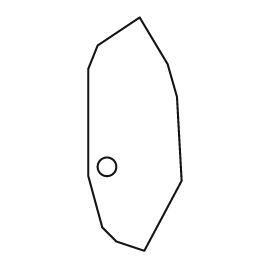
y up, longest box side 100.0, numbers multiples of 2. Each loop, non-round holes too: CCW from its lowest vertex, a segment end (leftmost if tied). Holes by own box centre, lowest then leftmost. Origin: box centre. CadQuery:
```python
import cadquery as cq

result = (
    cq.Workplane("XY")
    .moveTo(4.0, -50.0)
    .lineTo(20.0, -20.0)
    .lineTo(18.0, 16.0)
    .lineTo(14.0, 30.0)
    .lineTo(2.0, 50.0)
    .lineTo(-16.0, 38.0)
    .lineTo(-20.0, 28.0)
    .lineTo(-20.0, -18.0)
    .lineTo(-14.0, -40.0)
    .lineTo(-8.0, -46.0)
    .close()
    .moveTo(-12.0, -14.0)
    .circle(4.0)
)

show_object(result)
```